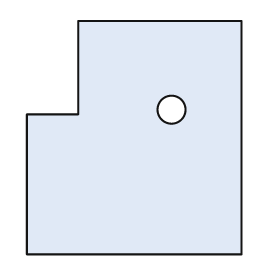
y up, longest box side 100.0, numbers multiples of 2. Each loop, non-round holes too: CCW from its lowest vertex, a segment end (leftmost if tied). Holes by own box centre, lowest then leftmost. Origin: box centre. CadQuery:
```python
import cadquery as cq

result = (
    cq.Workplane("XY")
    .moveTo(-46.0, -50.0)
    .lineTo(46.0, -50.0)
    .lineTo(46.0, 50.0)
    .lineTo(-24.0, 50.0)
    .lineTo(-24.0, 10.0)
    .lineTo(-46.0, 10.0)
    .close()
    .moveTo(16.0, 12.0)
    .circle(6.0)
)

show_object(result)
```